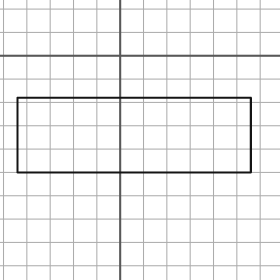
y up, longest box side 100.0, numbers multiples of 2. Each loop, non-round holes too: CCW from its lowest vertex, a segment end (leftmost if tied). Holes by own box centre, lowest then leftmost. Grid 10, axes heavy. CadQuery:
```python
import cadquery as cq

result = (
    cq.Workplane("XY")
    .moveTo(-44.0, -50.0)
    .lineTo(56.0, -50.0)
    .lineTo(56.0, -18.0)
    .lineTo(-44.0, -18.0)
    .close()
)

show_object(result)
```